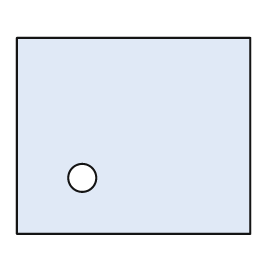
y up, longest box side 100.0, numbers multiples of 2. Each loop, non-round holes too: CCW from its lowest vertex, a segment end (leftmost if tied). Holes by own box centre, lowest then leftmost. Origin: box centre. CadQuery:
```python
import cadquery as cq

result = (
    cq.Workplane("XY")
    .moveTo(-50.0, -42.0)
    .lineTo(50.0, -42.0)
    .lineTo(50.0, 42.0)
    .lineTo(-50.0, 42.0)
    .close()
    .moveTo(-22.0, -18.0)
    .circle(6.0)
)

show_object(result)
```